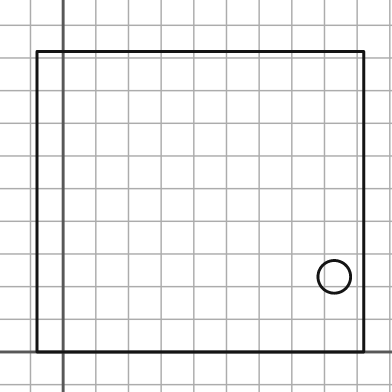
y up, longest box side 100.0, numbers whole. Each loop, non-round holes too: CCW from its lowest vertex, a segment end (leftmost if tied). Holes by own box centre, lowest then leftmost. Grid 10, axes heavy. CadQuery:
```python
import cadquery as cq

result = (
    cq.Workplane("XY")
    .moveTo(-8.0, 0.0)
    .lineTo(92.0, 0.0)
    .lineTo(92.0, 92.0)
    .lineTo(-8.0, 92.0)
    .close()
    .moveTo(83.0, 23.0)
    .circle(5.0)
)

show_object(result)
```